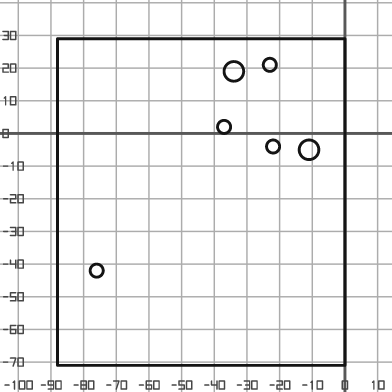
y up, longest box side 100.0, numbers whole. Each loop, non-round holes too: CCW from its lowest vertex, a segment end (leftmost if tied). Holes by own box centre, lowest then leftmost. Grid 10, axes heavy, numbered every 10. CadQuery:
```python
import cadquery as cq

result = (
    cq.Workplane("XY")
    .moveTo(-88.0, -71.0)
    .lineTo(0.0, -71.0)
    .lineTo(0.0, 29.0)
    .lineTo(-88.0, 29.0)
    .close()
    .moveTo(-76.0, -42.0)
    .circle(2.0)
    .moveTo(-11.0, -5.0)
    .circle(3.0)
    .moveTo(-22.0, -4.0)
    .circle(2.0)
    .moveTo(-37.0, 2.0)
    .circle(2.0)
    .moveTo(-34.0, 19.0)
    .circle(3.0)
    .moveTo(-23.0, 21.0)
    .circle(2.0)
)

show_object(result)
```